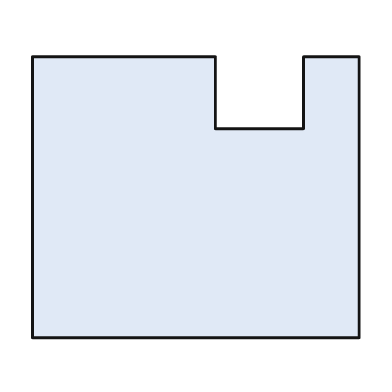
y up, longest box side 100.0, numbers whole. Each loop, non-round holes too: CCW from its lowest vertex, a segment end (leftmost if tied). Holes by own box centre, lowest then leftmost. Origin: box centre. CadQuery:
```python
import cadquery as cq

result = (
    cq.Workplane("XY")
    .moveTo(-50.0, -43.0)
    .lineTo(50.0, -43.0)
    .lineTo(50.0, 43.0)
    .lineTo(33.0, 43.0)
    .lineTo(33.0, 21.0)
    .lineTo(6.0, 21.0)
    .lineTo(6.0, 43.0)
    .lineTo(-50.0, 43.0)
    .close()
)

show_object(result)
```